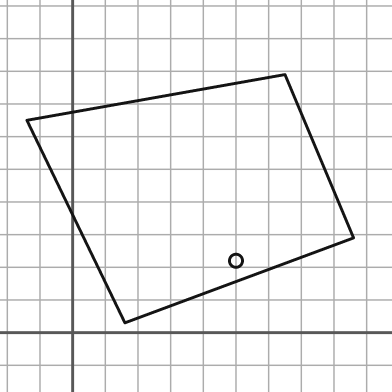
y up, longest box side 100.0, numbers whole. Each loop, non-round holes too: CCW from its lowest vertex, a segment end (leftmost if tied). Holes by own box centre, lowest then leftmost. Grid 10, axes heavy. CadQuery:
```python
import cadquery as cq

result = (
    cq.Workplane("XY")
    .moveTo(16.0, 3.0)
    .lineTo(86.0, 29.0)
    .lineTo(65.0, 79.0)
    .lineTo(-14.0, 65.0)
    .close()
    .moveTo(50.0, 22.0)
    .circle(2.0)
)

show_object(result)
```